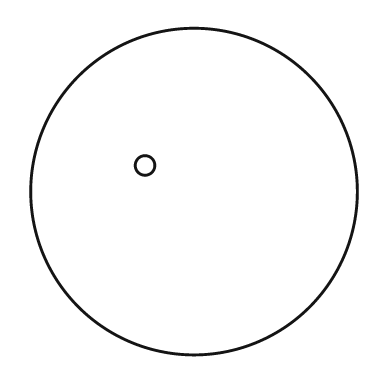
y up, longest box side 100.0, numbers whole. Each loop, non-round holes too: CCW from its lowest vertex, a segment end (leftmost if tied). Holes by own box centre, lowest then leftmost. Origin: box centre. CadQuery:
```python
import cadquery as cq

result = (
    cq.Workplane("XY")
    .moveTo(0.0, 0.0)
    .circle(50.0)
    .moveTo(-15.0, 8.0)
    .circle(3.0)
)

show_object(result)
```